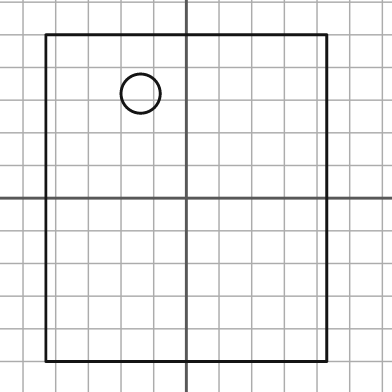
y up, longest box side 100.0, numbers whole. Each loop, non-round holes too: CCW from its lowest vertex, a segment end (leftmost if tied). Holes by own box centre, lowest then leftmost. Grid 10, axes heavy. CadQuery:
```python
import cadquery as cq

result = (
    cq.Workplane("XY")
    .moveTo(-43.0, -50.0)
    .lineTo(43.0, -50.0)
    .lineTo(43.0, 50.0)
    .lineTo(-43.0, 50.0)
    .close()
    .moveTo(-14.0, 32.0)
    .circle(6.0)
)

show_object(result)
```